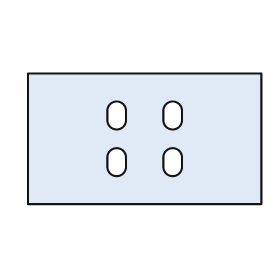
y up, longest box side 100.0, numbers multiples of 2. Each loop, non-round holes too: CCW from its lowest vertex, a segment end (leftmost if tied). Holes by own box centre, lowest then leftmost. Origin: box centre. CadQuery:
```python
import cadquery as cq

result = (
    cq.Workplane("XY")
    .moveTo(-50.0, -28.0)
    .lineTo(50.0, -28.0)
    .lineTo(50.0, 28.0)
    .lineTo(-50.0, 28.0)
    .close()
    .moveTo(-16.0, -12.0)
    .threePointArc((-12.0, -16.0), (-8.0, -12.0))
    .lineTo(-8.0, -8.0)
    .threePointArc((-12.0, -4.0), (-16.0, -8.0))
    .close()
    .moveTo(8.0, -12.0)
    .threePointArc((12.0, -16.0), (16.0, -12.0))
    .lineTo(16.0, -8.0)
    .threePointArc((12.0, -4.0), (8.0, -8.0))
    .close()
    .moveTo(-16.0, 8.0)
    .threePointArc((-12.0, 4.0), (-8.0, 8.0))
    .lineTo(-8.0, 12.0)
    .threePointArc((-12.0, 16.0), (-16.0, 12.0))
    .close()
    .moveTo(8.0, 8.0)
    .threePointArc((12.0, 4.0), (16.0, 8.0))
    .lineTo(16.0, 12.0)
    .threePointArc((12.0, 16.0), (8.0, 12.0))
    .close()
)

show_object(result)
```